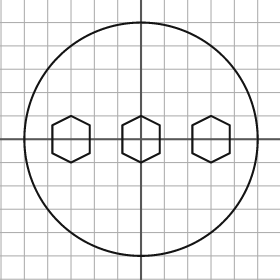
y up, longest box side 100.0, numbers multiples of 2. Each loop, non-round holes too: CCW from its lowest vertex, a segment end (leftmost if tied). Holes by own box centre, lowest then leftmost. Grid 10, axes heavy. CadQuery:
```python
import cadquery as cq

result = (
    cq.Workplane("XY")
    .moveTo(0.0, 0.0)
    .circle(50.0)
    .moveTo(-30.0, -10.0)
    .lineTo(-22.0, -6.0)
    .lineTo(-22.0, 6.0)
    .lineTo(-30.0, 10.0)
    .lineTo(-38.0, 6.0)
    .lineTo(-38.0, -6.0)
    .close()
    .moveTo(0.0, -10.0)
    .lineTo(8.0, -6.0)
    .lineTo(8.0, 6.0)
    .lineTo(0.0, 10.0)
    .lineTo(-8.0, 6.0)
    .lineTo(-8.0, -6.0)
    .close()
    .moveTo(30.0, -10.0)
    .lineTo(38.0, -6.0)
    .lineTo(38.0, 6.0)
    .lineTo(30.0, 10.0)
    .lineTo(22.0, 6.0)
    .lineTo(22.0, -6.0)
    .close()
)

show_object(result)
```